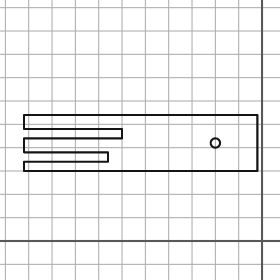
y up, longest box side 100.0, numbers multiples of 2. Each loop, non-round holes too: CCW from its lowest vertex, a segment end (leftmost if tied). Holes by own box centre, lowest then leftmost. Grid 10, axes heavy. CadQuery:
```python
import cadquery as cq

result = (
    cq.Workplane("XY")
    .moveTo(-102.0, 30.0)
    .lineTo(-2.0, 30.0)
    .lineTo(-2.0, 54.0)
    .lineTo(-102.0, 54.0)
    .lineTo(-102.0, 48.0)
    .lineTo(-60.0, 48.0)
    .lineTo(-60.0, 44.0)
    .lineTo(-102.0, 44.0)
    .lineTo(-102.0, 38.0)
    .lineTo(-66.0, 38.0)
    .lineTo(-66.0, 34.0)
    .lineTo(-102.0, 34.0)
    .close()
    .moveTo(-20.0, 42.0)
    .circle(2.0)
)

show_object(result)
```